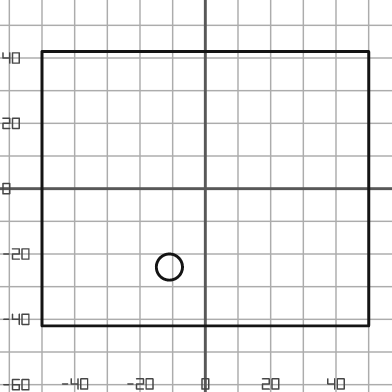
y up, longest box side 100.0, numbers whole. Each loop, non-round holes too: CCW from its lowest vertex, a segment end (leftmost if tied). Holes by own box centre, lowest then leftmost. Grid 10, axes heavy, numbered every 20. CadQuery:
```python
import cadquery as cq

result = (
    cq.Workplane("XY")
    .moveTo(-50.0, -42.0)
    .lineTo(50.0, -42.0)
    .lineTo(50.0, 42.0)
    .lineTo(-50.0, 42.0)
    .close()
    .moveTo(-11.0, -24.0)
    .circle(4.0)
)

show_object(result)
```